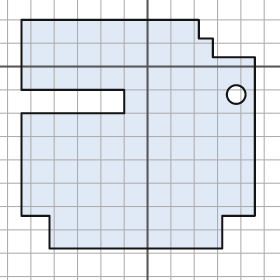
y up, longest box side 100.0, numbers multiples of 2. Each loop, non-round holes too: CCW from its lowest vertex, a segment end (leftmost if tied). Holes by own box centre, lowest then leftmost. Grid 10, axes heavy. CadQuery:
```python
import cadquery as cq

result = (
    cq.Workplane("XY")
    .moveTo(-42.0, -78.0)
    .lineTo(32.0, -78.0)
    .lineTo(32.0, -64.0)
    .lineTo(46.0, -64.0)
    .lineTo(46.0, 4.0)
    .lineTo(28.0, 4.0)
    .lineTo(28.0, 12.0)
    .lineTo(22.0, 12.0)
    .lineTo(22.0, 20.0)
    .lineTo(-54.0, 20.0)
    .lineTo(-54.0, -10.0)
    .lineTo(-10.0, -10.0)
    .lineTo(-10.0, -20.0)
    .lineTo(-54.0, -20.0)
    .lineTo(-54.0, -64.0)
    .lineTo(-42.0, -64.0)
    .close()
    .moveTo(38.0, -12.0)
    .circle(4.0)
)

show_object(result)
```